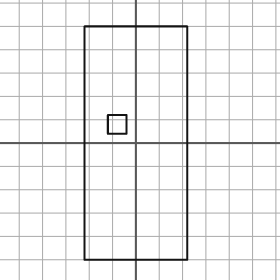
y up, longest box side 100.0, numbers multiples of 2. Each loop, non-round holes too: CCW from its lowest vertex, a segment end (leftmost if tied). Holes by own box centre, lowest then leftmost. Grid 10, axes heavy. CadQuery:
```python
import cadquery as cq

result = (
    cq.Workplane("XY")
    .moveTo(-22.0, -50.0)
    .lineTo(22.0, -50.0)
    .lineTo(22.0, 50.0)
    .lineTo(-22.0, 50.0)
    .close()
    .moveTo(-12.0, 4.0)
    .lineTo(-4.0, 4.0)
    .lineTo(-4.0, 12.0)
    .lineTo(-12.0, 12.0)
    .close()
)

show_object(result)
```